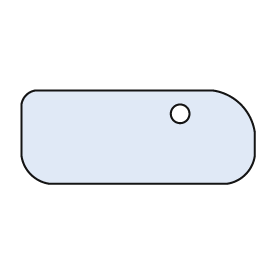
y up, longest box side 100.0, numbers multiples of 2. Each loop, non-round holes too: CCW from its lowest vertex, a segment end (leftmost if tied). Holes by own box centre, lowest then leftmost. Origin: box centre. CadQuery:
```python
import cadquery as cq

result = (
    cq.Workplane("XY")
    .moveTo(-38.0, -20.0)
    .lineTo(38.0, -20.0)
    .threePointArc((46.0, -16.0), (50.0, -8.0))
    .lineTo(50.0, 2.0)
    .threePointArc((44.0, 14.0), (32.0, 20.0))
    .lineTo(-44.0, 20.0)
    .threePointArc((-48.0, 18.0), (-50.0, 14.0))
    .lineTo(-50.0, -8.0)
    .threePointArc((-46.0, -16.0), (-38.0, -20.0))
    .close()
    .moveTo(18.0, 10.0)
    .circle(4.0)
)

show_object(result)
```